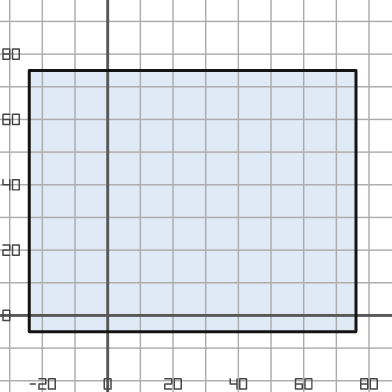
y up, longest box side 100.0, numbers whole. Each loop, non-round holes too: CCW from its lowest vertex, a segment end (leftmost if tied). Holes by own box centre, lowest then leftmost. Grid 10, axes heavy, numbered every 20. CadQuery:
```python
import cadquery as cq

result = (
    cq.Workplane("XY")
    .moveTo(-24.0, -5.0)
    .lineTo(76.0, -5.0)
    .lineTo(76.0, 75.0)
    .lineTo(-24.0, 75.0)
    .close()
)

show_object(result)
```